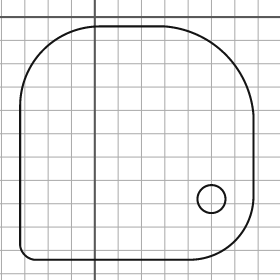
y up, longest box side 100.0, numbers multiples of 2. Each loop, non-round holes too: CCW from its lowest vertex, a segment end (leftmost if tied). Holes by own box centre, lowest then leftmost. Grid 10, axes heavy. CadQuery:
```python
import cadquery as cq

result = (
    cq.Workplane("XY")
    .moveTo(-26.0, -104.0)
    .lineTo(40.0, -104.0)
    .threePointArc((60.0, -96.0), (68.0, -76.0))
    .lineTo(68.0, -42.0)
    .threePointArc((56.0, -16.0), (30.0, -4.0))
    .lineTo(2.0, -4.0)
    .threePointArc((-22.0, -14.0), (-32.0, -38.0))
    .lineTo(-32.0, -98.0)
    .threePointArc((-30.0, -102.0), (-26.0, -104.0))
    .close()
    .moveTo(50.0, -78.0)
    .circle(6.0)
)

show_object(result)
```